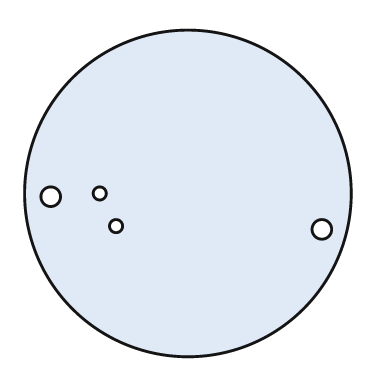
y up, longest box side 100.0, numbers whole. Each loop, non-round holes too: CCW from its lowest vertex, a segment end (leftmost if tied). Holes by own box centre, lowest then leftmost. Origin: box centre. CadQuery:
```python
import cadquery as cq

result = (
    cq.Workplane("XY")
    .moveTo(0.0, 0.0)
    .circle(50.0)
    .moveTo(41.0, -11.0)
    .circle(3.0)
    .moveTo(-22.0, -10.0)
    .circle(2.0)
    .moveTo(-42.0, -1.0)
    .circle(3.0)
    .moveTo(-27.0, 0.0)
    .circle(2.0)
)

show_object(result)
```